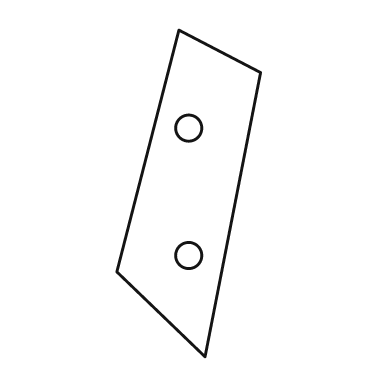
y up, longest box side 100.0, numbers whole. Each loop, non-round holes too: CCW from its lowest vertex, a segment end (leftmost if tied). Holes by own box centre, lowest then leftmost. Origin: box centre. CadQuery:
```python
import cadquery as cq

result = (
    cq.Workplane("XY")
    .moveTo(5.0, -50.0)
    .lineTo(22.0, 37.0)
    .lineTo(-3.0, 50.0)
    .lineTo(-22.0, -24.0)
    .close()
    .moveTo(0.0, -19.0)
    .circle(4.0)
    .moveTo(0.0, 20.0)
    .circle(4.0)
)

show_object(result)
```